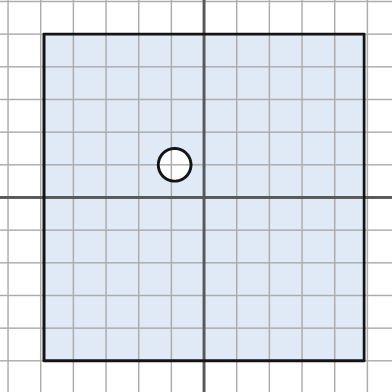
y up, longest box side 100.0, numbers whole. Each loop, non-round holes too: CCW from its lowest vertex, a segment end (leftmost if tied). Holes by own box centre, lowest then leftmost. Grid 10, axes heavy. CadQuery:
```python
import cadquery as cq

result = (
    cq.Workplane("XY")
    .moveTo(-49.0, -50.0)
    .lineTo(49.0, -50.0)
    .lineTo(49.0, 50.0)
    .lineTo(-49.0, 50.0)
    .close()
    .moveTo(-9.0, 10.0)
    .circle(5.0)
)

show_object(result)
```